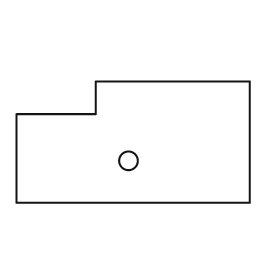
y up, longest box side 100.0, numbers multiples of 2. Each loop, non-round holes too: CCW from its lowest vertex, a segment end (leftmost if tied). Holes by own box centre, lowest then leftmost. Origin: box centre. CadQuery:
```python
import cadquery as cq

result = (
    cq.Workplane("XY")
    .moveTo(-50.0, -26.0)
    .lineTo(50.0, -26.0)
    .lineTo(50.0, 26.0)
    .lineTo(-16.0, 26.0)
    .lineTo(-16.0, 12.0)
    .lineTo(-50.0, 12.0)
    .close()
    .moveTo(-2.0, -8.0)
    .circle(4.0)
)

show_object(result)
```